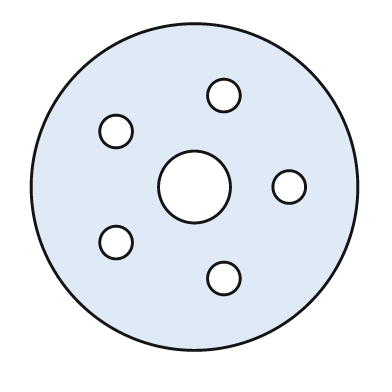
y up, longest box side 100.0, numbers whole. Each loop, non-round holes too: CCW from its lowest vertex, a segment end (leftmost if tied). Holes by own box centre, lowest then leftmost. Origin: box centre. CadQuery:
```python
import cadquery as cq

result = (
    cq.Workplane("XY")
    .moveTo(0.0, 0.0)
    .circle(50.0)
    .moveTo(9.0, -28.0)
    .circle(5.0)
    .moveTo(-24.0, -17.0)
    .circle(5.0)
    .moveTo(0.0, 0.0)
    .circle(11.0)
    .moveTo(29.0, 0.0)
    .circle(5.0)
    .moveTo(-24.0, 17.0)
    .circle(5.0)
    .moveTo(9.0, 28.0)
    .circle(5.0)
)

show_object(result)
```